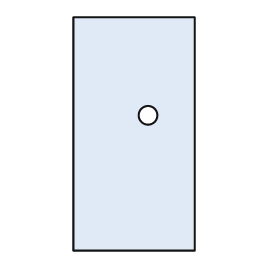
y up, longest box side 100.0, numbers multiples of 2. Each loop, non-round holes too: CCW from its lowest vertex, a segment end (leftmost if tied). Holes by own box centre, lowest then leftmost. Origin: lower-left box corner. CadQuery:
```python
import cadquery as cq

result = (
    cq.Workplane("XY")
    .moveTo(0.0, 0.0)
    .lineTo(52.0, 0.0)
    .lineTo(52.0, 100.0)
    .lineTo(0.0, 100.0)
    .close()
    .moveTo(32.0, 58.0)
    .circle(4.0)
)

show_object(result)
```